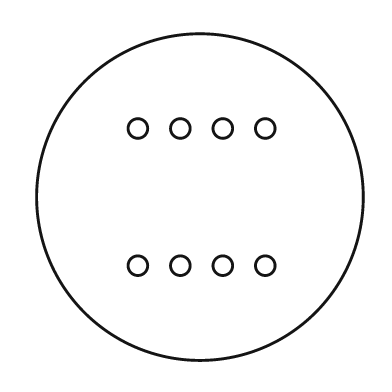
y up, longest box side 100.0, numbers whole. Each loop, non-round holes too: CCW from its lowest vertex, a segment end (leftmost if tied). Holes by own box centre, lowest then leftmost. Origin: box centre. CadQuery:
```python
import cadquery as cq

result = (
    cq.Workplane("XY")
    .moveTo(0.0, 0.0)
    .circle(50.0)
    .moveTo(-19.0, -21.0)
    .circle(3.0)
    .moveTo(-6.0, -21.0)
    .circle(3.0)
    .moveTo(7.0, -21.0)
    .circle(3.0)
    .moveTo(20.0, -21.0)
    .circle(3.0)
    .moveTo(-19.0, 21.0)
    .circle(3.0)
    .moveTo(-6.0, 21.0)
    .circle(3.0)
    .moveTo(7.0, 21.0)
    .circle(3.0)
    .moveTo(20.0, 21.0)
    .circle(3.0)
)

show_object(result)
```